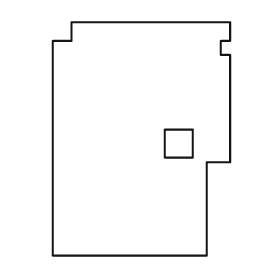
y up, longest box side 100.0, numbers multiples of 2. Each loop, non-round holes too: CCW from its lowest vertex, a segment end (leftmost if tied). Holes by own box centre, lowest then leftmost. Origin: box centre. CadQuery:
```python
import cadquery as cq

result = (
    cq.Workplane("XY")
    .moveTo(-38.0, -50.0)
    .lineTo(28.0, -50.0)
    .lineTo(28.0, -10.0)
    .lineTo(38.0, -10.0)
    .lineTo(38.0, 36.0)
    .lineTo(34.0, 36.0)
    .lineTo(34.0, 42.0)
    .lineTo(38.0, 42.0)
    .lineTo(38.0, 50.0)
    .lineTo(-30.0, 50.0)
    .lineTo(-30.0, 42.0)
    .lineTo(-38.0, 42.0)
    .close()
    .moveTo(10.0, -8.0)
    .lineTo(22.0, -8.0)
    .lineTo(22.0, 4.0)
    .lineTo(10.0, 4.0)
    .close()
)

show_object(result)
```